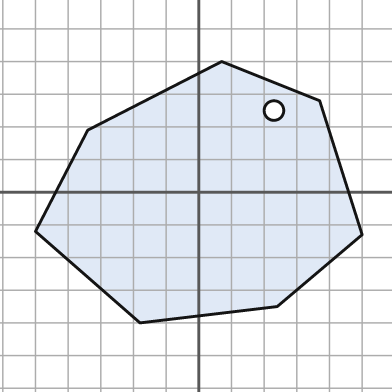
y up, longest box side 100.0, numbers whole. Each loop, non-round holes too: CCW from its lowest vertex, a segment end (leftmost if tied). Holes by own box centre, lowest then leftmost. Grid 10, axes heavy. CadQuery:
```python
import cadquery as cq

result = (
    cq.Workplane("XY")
    .moveTo(-18.0, -40.0)
    .lineTo(24.0, -35.0)
    .lineTo(50.0, -13.0)
    .lineTo(37.0, 28.0)
    .lineTo(7.0, 40.0)
    .lineTo(-34.0, 19.0)
    .lineTo(-50.0, -12.0)
    .close()
    .moveTo(23.0, 25.0)
    .circle(3.0)
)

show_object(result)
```